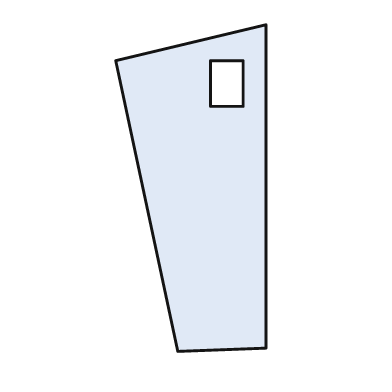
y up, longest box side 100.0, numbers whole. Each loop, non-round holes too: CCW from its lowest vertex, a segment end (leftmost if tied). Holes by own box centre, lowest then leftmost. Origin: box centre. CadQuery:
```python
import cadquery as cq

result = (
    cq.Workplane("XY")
    .moveTo(-4.0, -50.0)
    .lineTo(23.0, -49.0)
    .lineTo(23.0, 50.0)
    .lineTo(-23.0, 39.0)
    .close()
    .moveTo(6.0, 25.0)
    .lineTo(16.0, 25.0)
    .lineTo(16.0, 39.0)
    .lineTo(6.0, 39.0)
    .close()
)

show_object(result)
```